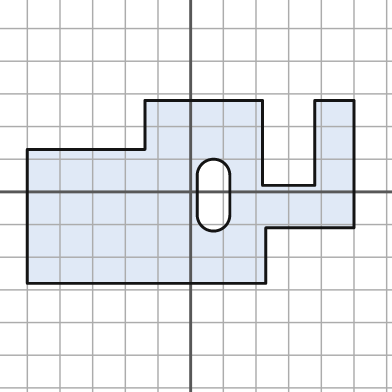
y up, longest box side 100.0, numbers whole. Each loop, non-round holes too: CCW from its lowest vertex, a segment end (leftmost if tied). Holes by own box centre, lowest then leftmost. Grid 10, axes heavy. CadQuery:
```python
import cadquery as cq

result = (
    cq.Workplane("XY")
    .moveTo(-50.0, -28.0)
    .lineTo(23.0, -28.0)
    .lineTo(23.0, -11.0)
    .lineTo(50.0, -11.0)
    .lineTo(50.0, 28.0)
    .lineTo(38.0, 28.0)
    .lineTo(38.0, 2.0)
    .lineTo(22.0, 2.0)
    .lineTo(22.0, 28.0)
    .lineTo(-14.0, 28.0)
    .lineTo(-14.0, 13.0)
    .lineTo(-50.0, 13.0)
    .close()
    .moveTo(2.0, -7.0)
    .threePointArc((7.0, -12.0), (12.0, -7.0))
    .lineTo(12.0, 5.0)
    .threePointArc((7.0, 10.0), (2.0, 5.0))
    .close()
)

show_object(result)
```